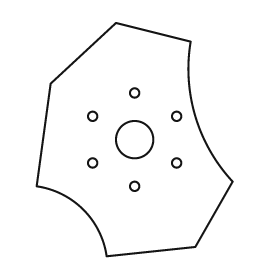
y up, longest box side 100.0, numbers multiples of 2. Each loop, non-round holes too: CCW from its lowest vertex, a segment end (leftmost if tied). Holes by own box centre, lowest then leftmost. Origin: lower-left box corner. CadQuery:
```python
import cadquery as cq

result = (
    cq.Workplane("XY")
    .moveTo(30.0, 0.0)
    .lineTo(68.0, 4.0)
    .lineTo(84.0, 32.0)
    .threePointArc((68.0, 60.0), (66.0, 92.0))
    .lineTo(34.0, 100.0)
    .lineTo(6.0, 74.0)
    .lineTo(0.0, 30.0)
    .threePointArc((20.0, 20.0), (30.0, 0.0))
    .close()
    .moveTo(42.0, 30.0)
    .circle(2.0)
    .moveTo(24.0, 40.0)
    .circle(2.0)
    .moveTo(60.0, 40.0)
    .circle(2.0)
    .moveTo(42.0, 50.0)
    .circle(8.0)
    .moveTo(24.0, 60.0)
    .circle(2.0)
    .moveTo(60.0, 60.0)
    .circle(2.0)
    .moveTo(42.0, 70.0)
    .circle(2.0)
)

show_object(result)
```